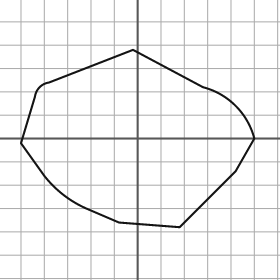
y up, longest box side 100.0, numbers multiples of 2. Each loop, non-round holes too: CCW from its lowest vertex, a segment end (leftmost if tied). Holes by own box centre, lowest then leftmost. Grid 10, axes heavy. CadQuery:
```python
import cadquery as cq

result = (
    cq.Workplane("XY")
    .moveTo(18.0, -38.0)
    .lineTo(42.0, -14.0)
    .lineTo(50.0, 0.0)
    .threePointArc((42.0, 14.0), (28.0, 22.0))
    .lineTo(-2.0, 38.0)
    .lineTo(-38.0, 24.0)
    .threePointArc((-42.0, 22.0), (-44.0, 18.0))
    .lineTo(-50.0, -2.0)
    .lineTo(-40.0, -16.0)
    .threePointArc((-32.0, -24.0), (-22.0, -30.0))
    .lineTo(-8.0, -36.0)
    .close()
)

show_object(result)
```